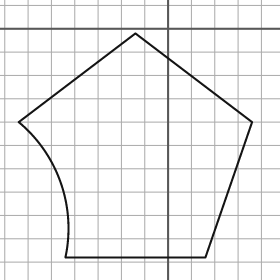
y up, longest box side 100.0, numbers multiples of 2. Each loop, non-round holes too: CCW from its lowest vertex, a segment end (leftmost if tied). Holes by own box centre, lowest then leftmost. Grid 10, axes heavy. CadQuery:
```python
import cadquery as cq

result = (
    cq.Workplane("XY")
    .moveTo(-44.0, -98.0)
    .lineTo(16.0, -98.0)
    .lineTo(36.0, -40.0)
    .lineTo(-14.0, -2.0)
    .lineTo(-64.0, -40.0)
    .threePointArc((-46.0, -66.0), (-44.0, -98.0))
    .close()
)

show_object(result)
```